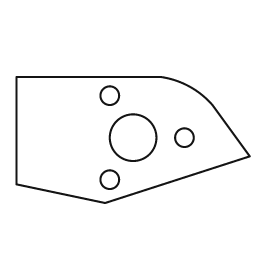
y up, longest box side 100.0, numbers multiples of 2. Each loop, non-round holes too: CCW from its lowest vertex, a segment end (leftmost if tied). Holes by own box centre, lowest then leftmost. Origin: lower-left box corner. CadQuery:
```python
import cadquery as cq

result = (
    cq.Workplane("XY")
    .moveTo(38.0, 0.0)
    .lineTo(100.0, 20.0)
    .lineTo(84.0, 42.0)
    .threePointArc((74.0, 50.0), (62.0, 54.0))
    .lineTo(0.0, 54.0)
    .lineTo(0.0, 8.0)
    .close()
    .moveTo(40.0, 10.0)
    .circle(4.0)
    .moveTo(50.0, 28.0)
    .circle(10.0)
    .moveTo(72.0, 28.0)
    .circle(4.0)
    .moveTo(40.0, 46.0)
    .circle(4.0)
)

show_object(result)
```